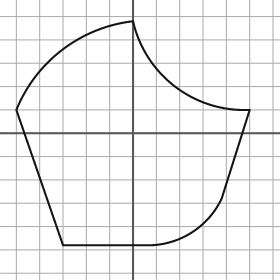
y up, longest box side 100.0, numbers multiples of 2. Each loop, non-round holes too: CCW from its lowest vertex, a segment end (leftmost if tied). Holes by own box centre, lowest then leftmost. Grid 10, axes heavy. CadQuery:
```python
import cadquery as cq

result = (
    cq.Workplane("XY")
    .moveTo(-30.0, -48.0)
    .lineTo(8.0, -48.0)
    .threePointArc((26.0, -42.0), (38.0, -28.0))
    .lineTo(50.0, 10.0)
    .threePointArc((18.0, 20.0), (0.0, 48.0))
    .threePointArc((-30.0, 36.0), (-50.0, 10.0))
    .close()
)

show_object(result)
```